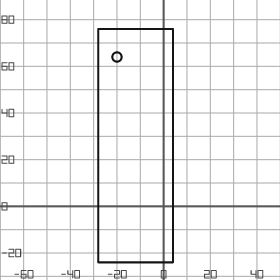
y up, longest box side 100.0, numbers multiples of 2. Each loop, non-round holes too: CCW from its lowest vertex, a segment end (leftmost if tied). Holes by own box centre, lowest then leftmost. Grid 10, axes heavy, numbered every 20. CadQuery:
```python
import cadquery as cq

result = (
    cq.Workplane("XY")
    .moveTo(-28.0, -24.0)
    .lineTo(4.0, -24.0)
    .lineTo(4.0, 76.0)
    .lineTo(-28.0, 76.0)
    .close()
    .moveTo(-20.0, 64.0)
    .circle(2.0)
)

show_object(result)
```